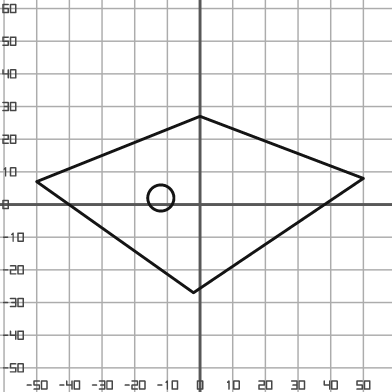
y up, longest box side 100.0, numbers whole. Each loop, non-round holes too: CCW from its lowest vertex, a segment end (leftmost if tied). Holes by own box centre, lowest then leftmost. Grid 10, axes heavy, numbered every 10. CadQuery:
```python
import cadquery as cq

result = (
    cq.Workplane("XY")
    .moveTo(-2.0, -27.0)
    .lineTo(50.0, 8.0)
    .lineTo(0.0, 27.0)
    .lineTo(-50.0, 7.0)
    .close()
    .moveTo(-12.0, 2.0)
    .circle(4.0)
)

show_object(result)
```